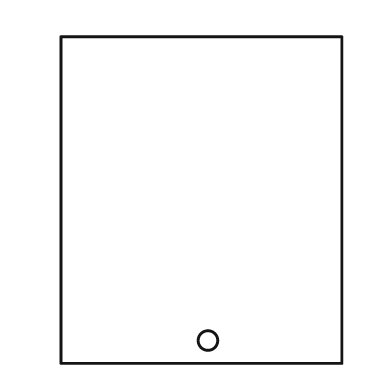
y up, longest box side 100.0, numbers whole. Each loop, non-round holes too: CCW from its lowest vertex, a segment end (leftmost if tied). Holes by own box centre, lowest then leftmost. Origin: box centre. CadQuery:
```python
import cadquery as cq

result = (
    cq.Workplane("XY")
    .moveTo(-43.0, -50.0)
    .lineTo(43.0, -50.0)
    .lineTo(43.0, 50.0)
    .lineTo(-43.0, 50.0)
    .close()
    .moveTo(2.0, -43.0)
    .circle(3.0)
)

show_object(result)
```